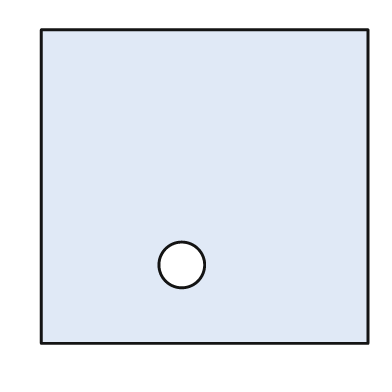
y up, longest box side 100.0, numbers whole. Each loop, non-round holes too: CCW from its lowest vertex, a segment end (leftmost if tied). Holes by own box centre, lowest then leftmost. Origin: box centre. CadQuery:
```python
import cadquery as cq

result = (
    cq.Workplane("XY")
    .moveTo(-50.0, -48.0)
    .lineTo(50.0, -48.0)
    .lineTo(50.0, 48.0)
    .lineTo(-50.0, 48.0)
    .close()
    .moveTo(-7.0, -24.0)
    .circle(7.0)
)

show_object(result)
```